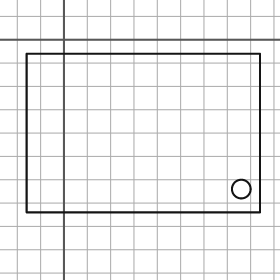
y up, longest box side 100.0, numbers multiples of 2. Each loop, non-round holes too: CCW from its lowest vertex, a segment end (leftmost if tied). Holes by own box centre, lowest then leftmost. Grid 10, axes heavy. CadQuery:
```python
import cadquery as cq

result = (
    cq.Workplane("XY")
    .moveTo(-16.0, -74.0)
    .lineTo(84.0, -74.0)
    .lineTo(84.0, -6.0)
    .lineTo(-16.0, -6.0)
    .close()
    .moveTo(76.0, -64.0)
    .circle(4.0)
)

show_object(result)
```